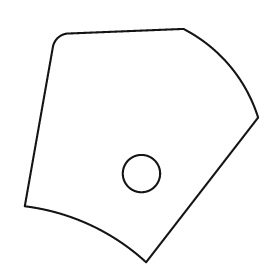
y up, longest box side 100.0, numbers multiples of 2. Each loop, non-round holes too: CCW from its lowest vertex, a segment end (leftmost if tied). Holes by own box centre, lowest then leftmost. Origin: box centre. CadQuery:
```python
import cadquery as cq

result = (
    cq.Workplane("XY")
    .moveTo(2.0, -50.0)
    .lineTo(50.0, 12.0)
    .threePointArc((38.0, 34.0), (18.0, 50.0))
    .lineTo(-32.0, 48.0)
    .threePointArc((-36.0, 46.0), (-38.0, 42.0))
    .lineTo(-50.0, -26.0)
    .threePointArc((-22.0, -34.0), (2.0, -50.0))
    .close()
    .moveTo(0.0, -12.0)
    .circle(8.0)
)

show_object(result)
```